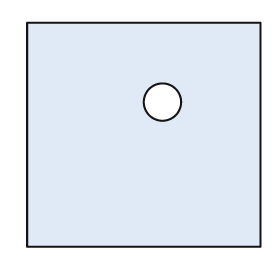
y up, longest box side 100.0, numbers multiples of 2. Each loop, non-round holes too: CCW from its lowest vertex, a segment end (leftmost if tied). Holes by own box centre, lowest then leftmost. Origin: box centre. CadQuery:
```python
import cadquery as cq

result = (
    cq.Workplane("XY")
    .moveTo(-50.0, -48.0)
    .lineTo(50.0, -48.0)
    .lineTo(50.0, 48.0)
    .lineTo(-50.0, 48.0)
    .close()
    .moveTo(8.0, 14.0)
    .circle(8.0)
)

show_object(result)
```